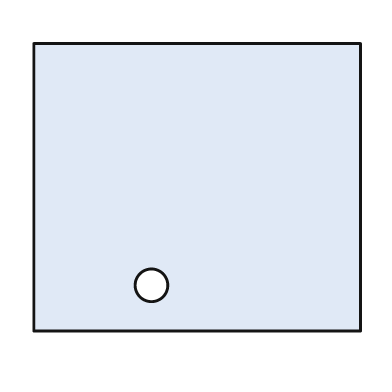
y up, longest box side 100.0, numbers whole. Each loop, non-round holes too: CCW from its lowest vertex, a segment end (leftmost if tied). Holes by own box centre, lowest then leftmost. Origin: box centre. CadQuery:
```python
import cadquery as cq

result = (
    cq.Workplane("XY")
    .moveTo(-50.0, -44.0)
    .lineTo(50.0, -44.0)
    .lineTo(50.0, 44.0)
    .lineTo(-50.0, 44.0)
    .close()
    .moveTo(-14.0, -30.0)
    .circle(5.0)
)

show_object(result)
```